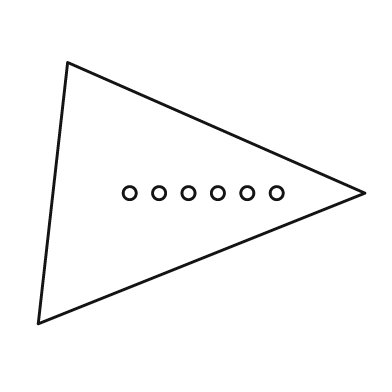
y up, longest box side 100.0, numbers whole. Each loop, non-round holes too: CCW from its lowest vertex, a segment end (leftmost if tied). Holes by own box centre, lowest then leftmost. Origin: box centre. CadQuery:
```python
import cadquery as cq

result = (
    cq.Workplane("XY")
    .moveTo(-50.0, -40.0)
    .lineTo(50.0, 0.0)
    .lineTo(-41.0, 40.0)
    .close()
    .moveTo(-22.0, 0.0)
    .circle(2.0)
    .moveTo(-13.0, 0.0)
    .circle(2.0)
    .moveTo(-4.0, 0.0)
    .circle(2.0)
    .moveTo(5.0, 0.0)
    .circle(2.0)
    .moveTo(14.0, 0.0)
    .circle(2.0)
    .moveTo(23.0, 0.0)
    .circle(2.0)
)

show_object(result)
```